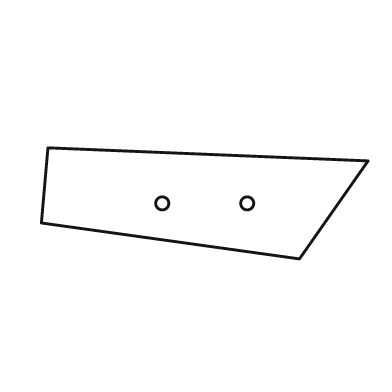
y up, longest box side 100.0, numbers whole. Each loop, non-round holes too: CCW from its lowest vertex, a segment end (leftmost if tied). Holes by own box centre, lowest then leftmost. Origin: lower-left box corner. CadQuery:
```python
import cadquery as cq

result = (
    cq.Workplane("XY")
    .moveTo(79.0, 0.0)
    .lineTo(100.0, 30.0)
    .lineTo(2.0, 34.0)
    .lineTo(0.0, 11.0)
    .close()
    .moveTo(37.0, 17.0)
    .circle(2.0)
    .moveTo(63.0, 17.0)
    .circle(2.0)
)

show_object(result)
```